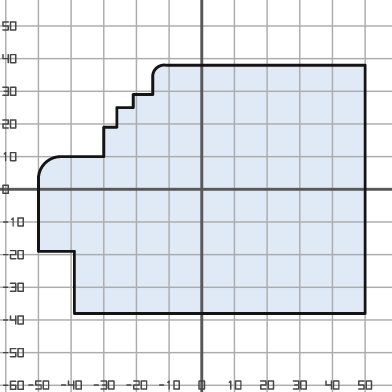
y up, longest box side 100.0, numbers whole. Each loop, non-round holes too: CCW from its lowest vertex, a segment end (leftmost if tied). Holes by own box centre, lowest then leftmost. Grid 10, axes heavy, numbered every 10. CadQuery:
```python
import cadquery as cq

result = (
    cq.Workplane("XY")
    .moveTo(-39.0, -38.0)
    .lineTo(50.0, -38.0)
    .lineTo(50.0, 38.0)
    .lineTo(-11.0, 38.0)
    .threePointArc((-14.0, 37.0), (-15.0, 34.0))
    .lineTo(-15.0, 29.0)
    .lineTo(-21.0, 29.0)
    .lineTo(-21.0, 25.0)
    .lineTo(-26.0, 25.0)
    .lineTo(-26.0, 19.0)
    .lineTo(-30.0, 19.0)
    .lineTo(-30.0, 10.0)
    .lineTo(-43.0, 10.0)
    .threePointArc((-48.0, 8.0), (-50.0, 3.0))
    .lineTo(-50.0, -19.0)
    .lineTo(-39.0, -19.0)
    .close()
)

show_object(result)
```